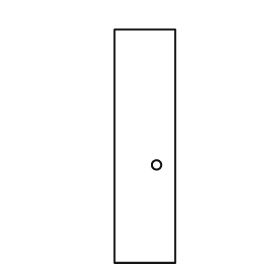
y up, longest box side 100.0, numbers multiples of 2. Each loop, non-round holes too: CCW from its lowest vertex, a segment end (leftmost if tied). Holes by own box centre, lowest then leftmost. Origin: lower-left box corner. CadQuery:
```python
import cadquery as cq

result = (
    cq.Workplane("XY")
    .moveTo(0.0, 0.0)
    .lineTo(26.0, 0.0)
    .lineTo(26.0, 100.0)
    .lineTo(0.0, 100.0)
    .close()
    .moveTo(18.0, 42.0)
    .circle(2.0)
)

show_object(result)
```